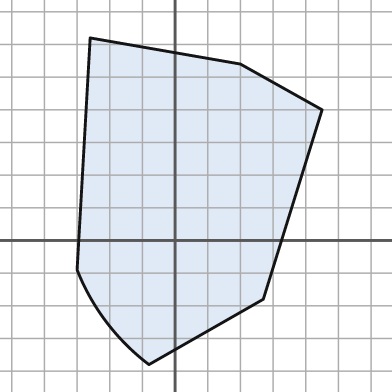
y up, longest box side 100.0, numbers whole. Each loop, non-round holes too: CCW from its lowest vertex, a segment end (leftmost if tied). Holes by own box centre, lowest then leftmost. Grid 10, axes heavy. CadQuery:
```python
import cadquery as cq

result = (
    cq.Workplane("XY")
    .moveTo(-8.0, -38.0)
    .lineTo(27.0, -18.0)
    .lineTo(45.0, 40.0)
    .lineTo(20.0, 54.0)
    .lineTo(-26.0, 62.0)
    .lineTo(-30.0, -9.0)
    .threePointArc((-21.0, -25.0), (-8.0, -38.0))
    .close()
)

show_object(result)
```